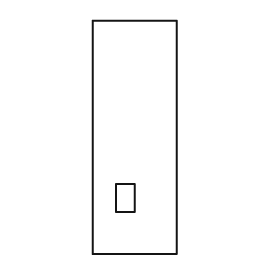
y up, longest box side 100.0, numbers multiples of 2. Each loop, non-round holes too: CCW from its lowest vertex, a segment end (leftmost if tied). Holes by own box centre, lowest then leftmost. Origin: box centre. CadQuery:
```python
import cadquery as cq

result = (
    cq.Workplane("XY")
    .moveTo(-18.0, -50.0)
    .lineTo(18.0, -50.0)
    .lineTo(18.0, 50.0)
    .lineTo(-18.0, 50.0)
    .close()
    .moveTo(-8.0, -32.0)
    .lineTo(0.0, -32.0)
    .lineTo(0.0, -20.0)
    .lineTo(-8.0, -20.0)
    .close()
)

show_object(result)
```